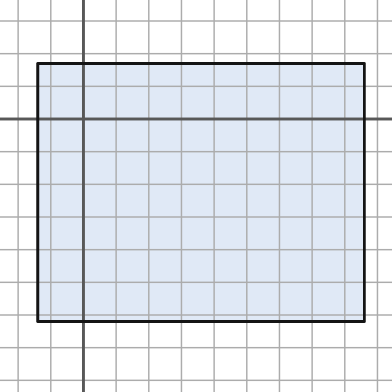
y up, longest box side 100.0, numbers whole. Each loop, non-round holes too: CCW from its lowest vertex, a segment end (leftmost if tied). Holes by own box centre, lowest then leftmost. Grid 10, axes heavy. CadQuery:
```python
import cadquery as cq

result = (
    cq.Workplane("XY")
    .moveTo(-14.0, -62.0)
    .lineTo(86.0, -62.0)
    .lineTo(86.0, 17.0)
    .lineTo(-14.0, 17.0)
    .close()
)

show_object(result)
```